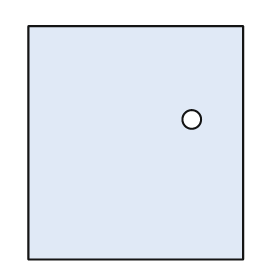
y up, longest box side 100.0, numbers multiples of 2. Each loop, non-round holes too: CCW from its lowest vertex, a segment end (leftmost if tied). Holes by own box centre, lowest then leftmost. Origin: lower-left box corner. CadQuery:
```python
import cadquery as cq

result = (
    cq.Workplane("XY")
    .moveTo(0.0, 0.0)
    .lineTo(92.0, 0.0)
    .lineTo(92.0, 100.0)
    .lineTo(0.0, 100.0)
    .close()
    .moveTo(70.0, 60.0)
    .circle(4.0)
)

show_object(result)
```